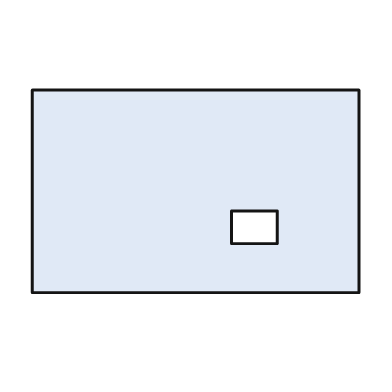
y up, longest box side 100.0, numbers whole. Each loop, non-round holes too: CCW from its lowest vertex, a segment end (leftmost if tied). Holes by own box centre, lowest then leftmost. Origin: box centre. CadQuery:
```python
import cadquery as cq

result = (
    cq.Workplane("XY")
    .moveTo(-50.0, -31.0)
    .lineTo(50.0, -31.0)
    .lineTo(50.0, 31.0)
    .lineTo(-50.0, 31.0)
    .close()
    .moveTo(11.0, -16.0)
    .lineTo(25.0, -16.0)
    .lineTo(25.0, -6.0)
    .lineTo(11.0, -6.0)
    .close()
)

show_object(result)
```